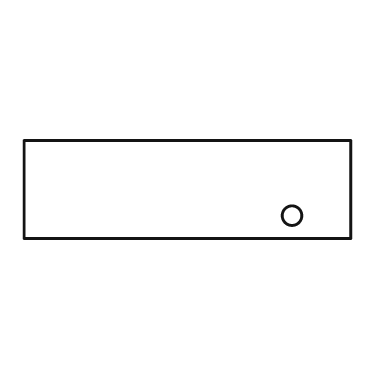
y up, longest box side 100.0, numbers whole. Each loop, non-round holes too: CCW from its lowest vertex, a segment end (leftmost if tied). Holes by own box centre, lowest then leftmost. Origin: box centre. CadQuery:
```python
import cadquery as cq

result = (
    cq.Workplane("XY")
    .moveTo(-50.0, -15.0)
    .lineTo(50.0, -15.0)
    .lineTo(50.0, 15.0)
    .lineTo(-50.0, 15.0)
    .close()
    .moveTo(32.0, -8.0)
    .circle(3.0)
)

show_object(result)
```